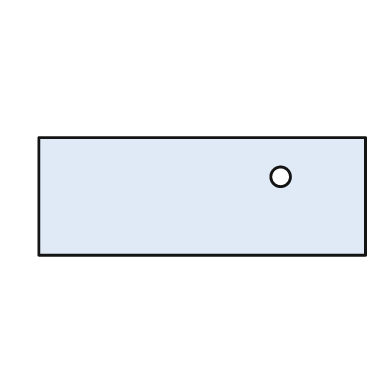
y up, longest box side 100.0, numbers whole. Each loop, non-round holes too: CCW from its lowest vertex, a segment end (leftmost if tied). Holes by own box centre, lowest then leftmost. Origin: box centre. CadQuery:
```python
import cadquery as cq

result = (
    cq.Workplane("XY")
    .moveTo(-50.0, -18.0)
    .lineTo(50.0, -18.0)
    .lineTo(50.0, 18.0)
    .lineTo(-50.0, 18.0)
    .close()
    .moveTo(24.0, 6.0)
    .circle(3.0)
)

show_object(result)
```